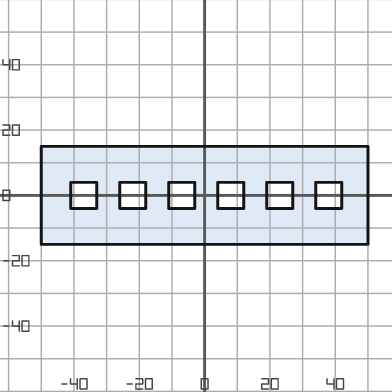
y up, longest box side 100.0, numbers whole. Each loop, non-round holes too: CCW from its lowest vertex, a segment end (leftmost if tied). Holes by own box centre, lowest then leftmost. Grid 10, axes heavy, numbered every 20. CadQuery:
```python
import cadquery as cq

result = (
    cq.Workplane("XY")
    .moveTo(-50.0, -15.0)
    .lineTo(50.0, -15.0)
    .lineTo(50.0, 15.0)
    .lineTo(-50.0, 15.0)
    .close()
    .moveTo(-41.0, -4.0)
    .lineTo(-33.0, -4.0)
    .lineTo(-33.0, 4.0)
    .lineTo(-41.0, 4.0)
    .close()
    .moveTo(-26.0, -4.0)
    .lineTo(-18.0, -4.0)
    .lineTo(-18.0, 4.0)
    .lineTo(-26.0, 4.0)
    .close()
    .moveTo(-11.0, -4.0)
    .lineTo(-3.0, -4.0)
    .lineTo(-3.0, 4.0)
    .lineTo(-11.0, 4.0)
    .close()
    .moveTo(4.0, -4.0)
    .lineTo(12.0, -4.0)
    .lineTo(12.0, 4.0)
    .lineTo(4.0, 4.0)
    .close()
    .moveTo(19.0, -4.0)
    .lineTo(27.0, -4.0)
    .lineTo(27.0, 4.0)
    .lineTo(19.0, 4.0)
    .close()
    .moveTo(34.0, -4.0)
    .lineTo(42.0, -4.0)
    .lineTo(42.0, 4.0)
    .lineTo(34.0, 4.0)
    .close()
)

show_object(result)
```